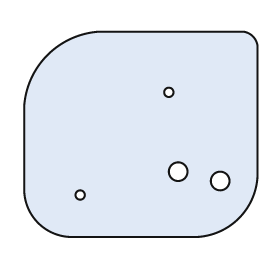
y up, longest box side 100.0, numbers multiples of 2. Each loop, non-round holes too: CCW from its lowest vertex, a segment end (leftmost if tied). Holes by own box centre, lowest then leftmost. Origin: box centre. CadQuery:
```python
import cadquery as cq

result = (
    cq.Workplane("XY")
    .moveTo(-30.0, -44.0)
    .lineTo(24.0, -44.0)
    .threePointArc((42.0, -36.0), (50.0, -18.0))
    .lineTo(50.0, 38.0)
    .threePointArc((48.0, 42.0), (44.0, 44.0))
    .lineTo(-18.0, 44.0)
    .threePointArc((-40.0, 34.0), (-50.0, 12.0))
    .lineTo(-50.0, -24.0)
    .threePointArc((-44.0, -38.0), (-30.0, -44.0))
    .close()
    .moveTo(-26.0, -26.0)
    .circle(2.0)
    .moveTo(34.0, -20.0)
    .circle(4.0)
    .moveTo(16.0, -16.0)
    .circle(4.0)
    .moveTo(12.0, 18.0)
    .circle(2.0)
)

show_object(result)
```